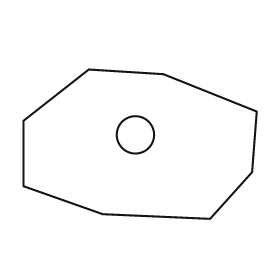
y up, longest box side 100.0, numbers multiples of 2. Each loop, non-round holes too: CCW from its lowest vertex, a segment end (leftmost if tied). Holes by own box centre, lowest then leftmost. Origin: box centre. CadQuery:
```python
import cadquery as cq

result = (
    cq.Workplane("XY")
    .moveTo(30.0, -32.0)
    .lineTo(48.0, -12.0)
    .lineTo(50.0, 14.0)
    .lineTo(10.0, 30.0)
    .lineTo(-22.0, 32.0)
    .lineTo(-50.0, 10.0)
    .lineTo(-50.0, -18.0)
    .lineTo(-16.0, -30.0)
    .close()
    .moveTo(-2.0, 4.0)
    .circle(8.0)
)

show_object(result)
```